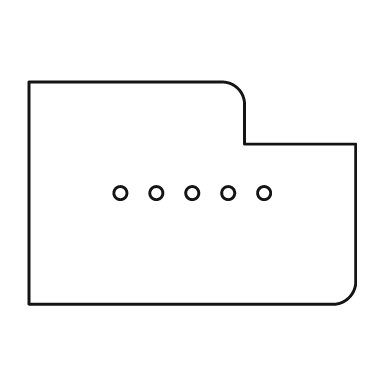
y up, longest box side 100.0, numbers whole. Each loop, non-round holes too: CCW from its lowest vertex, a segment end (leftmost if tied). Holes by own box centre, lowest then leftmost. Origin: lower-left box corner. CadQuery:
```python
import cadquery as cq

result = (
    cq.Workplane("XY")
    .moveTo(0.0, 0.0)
    .lineTo(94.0, 0.0)
    .threePointArc((98.0, 2.0), (100.0, 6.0))
    .lineTo(100.0, 49.0)
    .lineTo(66.0, 49.0)
    .lineTo(66.0, 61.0)
    .threePointArc((64.0, 66.0), (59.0, 68.0))
    .lineTo(0.0, 68.0)
    .close()
    .moveTo(28.0, 34.0)
    .circle(2.0)
    .moveTo(39.0, 34.0)
    .circle(2.0)
    .moveTo(50.0, 34.0)
    .circle(2.0)
    .moveTo(61.0, 34.0)
    .circle(2.0)
    .moveTo(72.0, 34.0)
    .circle(2.0)
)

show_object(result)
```